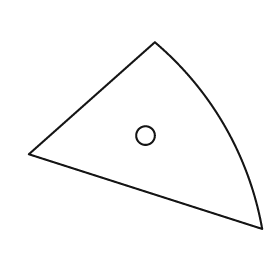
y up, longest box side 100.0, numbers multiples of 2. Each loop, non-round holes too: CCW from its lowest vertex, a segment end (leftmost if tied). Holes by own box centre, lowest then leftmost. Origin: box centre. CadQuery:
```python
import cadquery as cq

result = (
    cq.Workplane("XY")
    .moveTo(50.0, -40.0)
    .threePointArc((34.0, 4.0), (4.0, 40.0))
    .lineTo(-50.0, -8.0)
    .close()
    .moveTo(0.0, 0.0)
    .circle(4.0)
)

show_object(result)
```